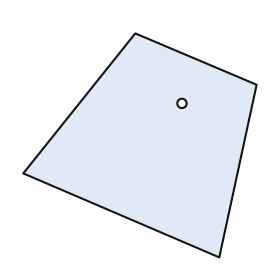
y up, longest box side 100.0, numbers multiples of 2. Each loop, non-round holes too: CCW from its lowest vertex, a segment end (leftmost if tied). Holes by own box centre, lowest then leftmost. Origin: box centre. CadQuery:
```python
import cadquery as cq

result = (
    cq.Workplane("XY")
    .moveTo(34.0, -48.0)
    .lineTo(50.0, 26.0)
    .lineTo(-2.0, 48.0)
    .lineTo(-50.0, -12.0)
    .close()
    .moveTo(18.0, 18.0)
    .circle(2.0)
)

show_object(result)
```